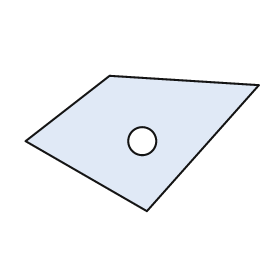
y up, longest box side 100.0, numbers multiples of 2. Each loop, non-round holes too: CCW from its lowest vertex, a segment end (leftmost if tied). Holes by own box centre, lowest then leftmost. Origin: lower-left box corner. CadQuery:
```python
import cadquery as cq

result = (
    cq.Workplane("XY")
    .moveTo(52.0, 0.0)
    .lineTo(100.0, 54.0)
    .lineTo(36.0, 58.0)
    .lineTo(0.0, 30.0)
    .close()
    .moveTo(50.0, 30.0)
    .circle(6.0)
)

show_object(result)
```